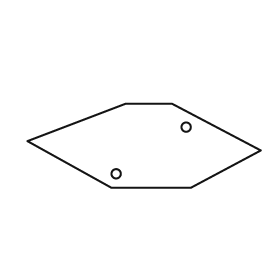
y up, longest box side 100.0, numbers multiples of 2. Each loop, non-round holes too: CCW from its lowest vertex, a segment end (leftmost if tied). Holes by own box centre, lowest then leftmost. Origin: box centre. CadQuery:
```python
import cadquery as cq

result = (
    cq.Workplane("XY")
    .moveTo(-14.0, -18.0)
    .lineTo(20.0, -18.0)
    .lineTo(50.0, -2.0)
    .lineTo(12.0, 18.0)
    .lineTo(-8.0, 18.0)
    .lineTo(-50.0, 2.0)
    .close()
    .moveTo(-12.0, -12.0)
    .circle(2.0)
    .moveTo(18.0, 8.0)
    .circle(2.0)
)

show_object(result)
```